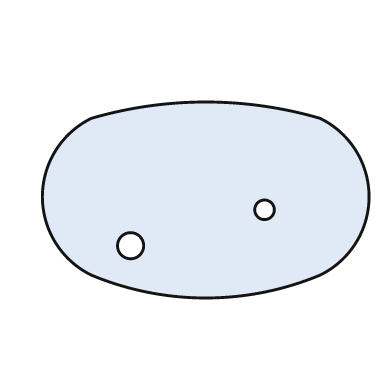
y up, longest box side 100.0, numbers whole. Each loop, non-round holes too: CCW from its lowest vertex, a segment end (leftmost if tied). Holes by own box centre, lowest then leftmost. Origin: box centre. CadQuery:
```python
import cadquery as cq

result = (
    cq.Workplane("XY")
    .moveTo(-35.0, -23.0)
    .threePointArc((0.0, -30.0), (35.0, -23.0))
    .threePointArc((50.0, 1.0), (35.0, 25.0))
    .threePointArc((0.0, 30.0), (-35.0, 25.0))
    .threePointArc((-50.0, 1.0), (-35.0, -23.0))
    .close()
    .moveTo(-23.0, -14.0)
    .circle(4.0)
    .moveTo(18.0, -3.0)
    .circle(3.0)
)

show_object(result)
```